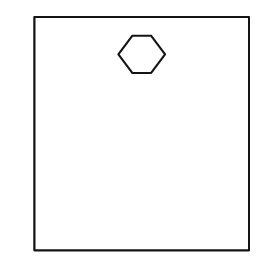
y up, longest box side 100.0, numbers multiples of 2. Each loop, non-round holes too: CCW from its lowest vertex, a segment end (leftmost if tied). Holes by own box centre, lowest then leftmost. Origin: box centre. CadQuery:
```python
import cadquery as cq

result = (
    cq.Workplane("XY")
    .moveTo(-46.0, -50.0)
    .lineTo(46.0, -50.0)
    .lineTo(46.0, 50.0)
    .lineTo(-46.0, 50.0)
    .close()
    .moveTo(-4.0, 26.0)
    .lineTo(4.0, 26.0)
    .lineTo(10.0, 34.0)
    .lineTo(4.0, 42.0)
    .lineTo(-4.0, 42.0)
    .lineTo(-10.0, 34.0)
    .close()
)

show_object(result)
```